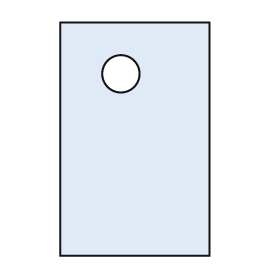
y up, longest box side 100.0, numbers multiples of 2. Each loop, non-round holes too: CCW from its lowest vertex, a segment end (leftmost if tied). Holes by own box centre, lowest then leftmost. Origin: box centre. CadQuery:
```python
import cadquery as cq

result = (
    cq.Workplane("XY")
    .moveTo(-32.0, -50.0)
    .lineTo(32.0, -50.0)
    .lineTo(32.0, 50.0)
    .lineTo(-32.0, 50.0)
    .close()
    .moveTo(-6.0, 28.0)
    .circle(8.0)
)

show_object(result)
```